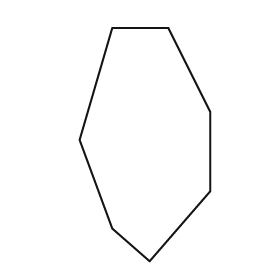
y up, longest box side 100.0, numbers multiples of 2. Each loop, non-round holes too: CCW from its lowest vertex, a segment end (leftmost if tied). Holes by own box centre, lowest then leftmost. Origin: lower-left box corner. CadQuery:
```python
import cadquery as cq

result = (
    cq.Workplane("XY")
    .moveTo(30.0, 0.0)
    .lineTo(56.0, 30.0)
    .lineTo(56.0, 64.0)
    .lineTo(38.0, 100.0)
    .lineTo(14.0, 100.0)
    .lineTo(0.0, 52.0)
    .lineTo(14.0, 14.0)
    .close()
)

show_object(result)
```